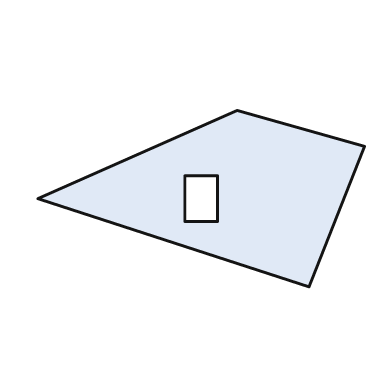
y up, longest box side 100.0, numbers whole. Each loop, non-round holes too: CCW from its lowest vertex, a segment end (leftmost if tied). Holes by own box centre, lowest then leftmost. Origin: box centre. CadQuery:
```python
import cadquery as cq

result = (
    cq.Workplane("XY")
    .moveTo(33.0, -27.0)
    .lineTo(50.0, 16.0)
    .lineTo(11.0, 27.0)
    .lineTo(-50.0, 0.0)
    .close()
    .moveTo(-5.0, -7.0)
    .lineTo(5.0, -7.0)
    .lineTo(5.0, 7.0)
    .lineTo(-5.0, 7.0)
    .close()
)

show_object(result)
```